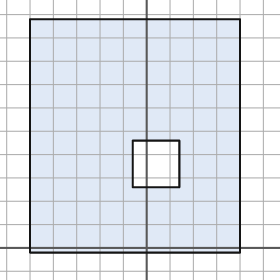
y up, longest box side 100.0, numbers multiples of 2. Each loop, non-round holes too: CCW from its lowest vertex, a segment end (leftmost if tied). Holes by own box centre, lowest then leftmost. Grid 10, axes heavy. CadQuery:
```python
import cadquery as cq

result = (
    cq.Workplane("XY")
    .moveTo(-50.0, -2.0)
    .lineTo(40.0, -2.0)
    .lineTo(40.0, 98.0)
    .lineTo(-50.0, 98.0)
    .close()
    .moveTo(-6.0, 26.0)
    .lineTo(14.0, 26.0)
    .lineTo(14.0, 46.0)
    .lineTo(-6.0, 46.0)
    .close()
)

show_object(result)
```